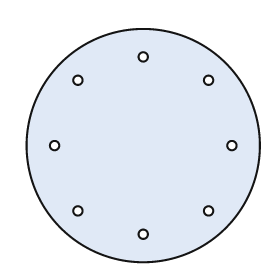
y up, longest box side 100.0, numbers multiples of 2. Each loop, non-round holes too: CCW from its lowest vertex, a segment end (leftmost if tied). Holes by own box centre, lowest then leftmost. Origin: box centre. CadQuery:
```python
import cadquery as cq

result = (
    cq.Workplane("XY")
    .moveTo(0.0, 0.0)
    .circle(50.0)
    .moveTo(0.0, -38.0)
    .circle(2.0)
    .moveTo(-28.0, -28.0)
    .circle(2.0)
    .moveTo(28.0, -28.0)
    .circle(2.0)
    .moveTo(-38.0, 0.0)
    .circle(2.0)
    .moveTo(38.0, 0.0)
    .circle(2.0)
    .moveTo(-28.0, 28.0)
    .circle(2.0)
    .moveTo(28.0, 28.0)
    .circle(2.0)
    .moveTo(0.0, 38.0)
    .circle(2.0)
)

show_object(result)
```